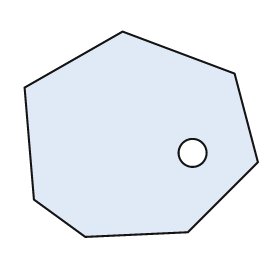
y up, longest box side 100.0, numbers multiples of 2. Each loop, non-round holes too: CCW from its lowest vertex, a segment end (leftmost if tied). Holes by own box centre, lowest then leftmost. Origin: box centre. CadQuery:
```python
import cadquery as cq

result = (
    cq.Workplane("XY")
    .moveTo(-24.0, -44.0)
    .lineTo(20.0, -42.0)
    .lineTo(50.0, -12.0)
    .lineTo(40.0, 26.0)
    .lineTo(-8.0, 44.0)
    .lineTo(-50.0, 20.0)
    .lineTo(-46.0, -28.0)
    .close()
    .moveTo(22.0, -8.0)
    .circle(6.0)
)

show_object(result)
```